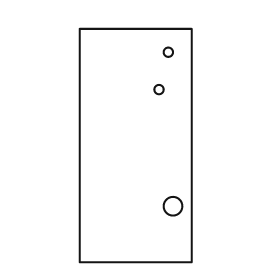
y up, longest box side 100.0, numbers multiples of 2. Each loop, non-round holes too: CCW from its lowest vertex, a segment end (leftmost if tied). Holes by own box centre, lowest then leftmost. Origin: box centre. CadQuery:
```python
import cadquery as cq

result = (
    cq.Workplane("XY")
    .moveTo(-24.0, -50.0)
    .lineTo(24.0, -50.0)
    .lineTo(24.0, 50.0)
    .lineTo(-24.0, 50.0)
    .close()
    .moveTo(16.0, -26.0)
    .circle(4.0)
    .moveTo(10.0, 24.0)
    .circle(2.0)
    .moveTo(14.0, 40.0)
    .circle(2.0)
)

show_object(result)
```